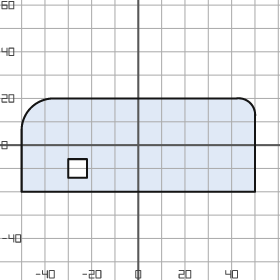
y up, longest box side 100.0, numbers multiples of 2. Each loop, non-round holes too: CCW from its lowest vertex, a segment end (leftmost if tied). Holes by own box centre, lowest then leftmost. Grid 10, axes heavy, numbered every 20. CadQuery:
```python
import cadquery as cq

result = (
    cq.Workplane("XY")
    .moveTo(-50.0, -20.0)
    .lineTo(50.0, -20.0)
    .lineTo(50.0, 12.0)
    .threePointArc((48.0, 18.0), (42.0, 20.0))
    .lineTo(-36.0, 20.0)
    .threePointArc((-46.0, 16.0), (-50.0, 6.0))
    .close()
    .moveTo(-30.0, -14.0)
    .lineTo(-22.0, -14.0)
    .lineTo(-22.0, -6.0)
    .lineTo(-30.0, -6.0)
    .close()
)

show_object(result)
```